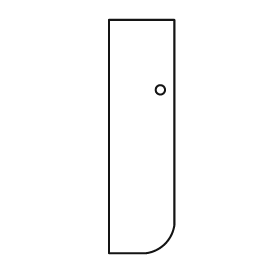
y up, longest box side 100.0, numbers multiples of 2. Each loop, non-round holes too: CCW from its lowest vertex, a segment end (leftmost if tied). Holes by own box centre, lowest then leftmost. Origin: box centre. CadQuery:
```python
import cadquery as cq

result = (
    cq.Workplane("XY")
    .moveTo(-14.0, -50.0)
    .lineTo(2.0, -50.0)
    .threePointArc((10.0, -46.0), (14.0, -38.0))
    .lineTo(14.0, 50.0)
    .lineTo(-14.0, 50.0)
    .close()
    .moveTo(8.0, 20.0)
    .circle(2.0)
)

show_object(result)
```